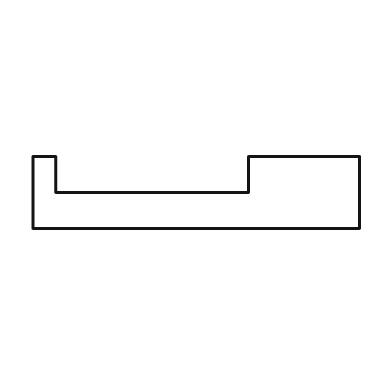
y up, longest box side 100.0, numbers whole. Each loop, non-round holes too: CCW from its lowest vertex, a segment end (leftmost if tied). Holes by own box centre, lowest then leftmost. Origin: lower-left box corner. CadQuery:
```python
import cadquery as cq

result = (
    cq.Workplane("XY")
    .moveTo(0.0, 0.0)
    .lineTo(100.0, 0.0)
    .lineTo(100.0, 22.0)
    .lineTo(66.0, 22.0)
    .lineTo(66.0, 11.0)
    .lineTo(7.0, 11.0)
    .lineTo(7.0, 22.0)
    .lineTo(0.0, 22.0)
    .close()
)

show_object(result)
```